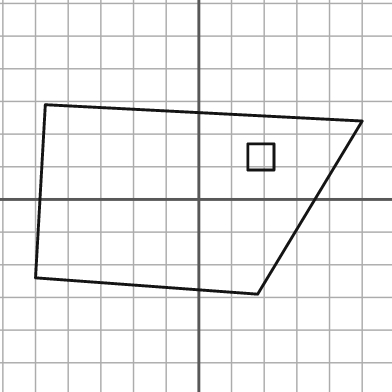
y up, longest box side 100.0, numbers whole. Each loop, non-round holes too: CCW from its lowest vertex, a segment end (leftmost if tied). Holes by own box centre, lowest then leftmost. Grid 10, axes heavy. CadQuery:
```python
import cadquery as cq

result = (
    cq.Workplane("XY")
    .moveTo(18.0, -29.0)
    .lineTo(50.0, 24.0)
    .lineTo(-47.0, 29.0)
    .lineTo(-50.0, -24.0)
    .close()
    .moveTo(15.0, 9.0)
    .lineTo(23.0, 9.0)
    .lineTo(23.0, 17.0)
    .lineTo(15.0, 17.0)
    .close()
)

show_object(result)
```